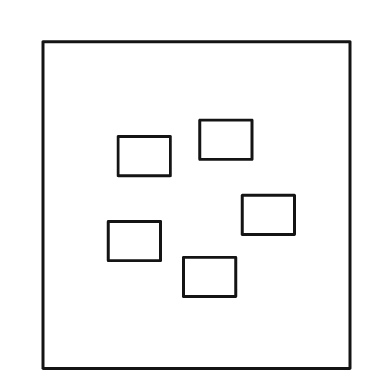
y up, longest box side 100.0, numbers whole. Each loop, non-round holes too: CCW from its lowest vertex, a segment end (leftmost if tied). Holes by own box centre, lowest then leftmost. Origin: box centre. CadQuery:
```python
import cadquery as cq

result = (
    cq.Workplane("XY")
    .moveTo(-47.0, -50.0)
    .lineTo(47.0, -50.0)
    .lineTo(47.0, 50.0)
    .lineTo(-47.0, 50.0)
    .close()
    .moveTo(-4.0, -28.0)
    .lineTo(12.0, -28.0)
    .lineTo(12.0, -16.0)
    .lineTo(-4.0, -16.0)
    .close()
    .moveTo(-27.0, -17.0)
    .lineTo(-11.0, -17.0)
    .lineTo(-11.0, -5.0)
    .lineTo(-27.0, -5.0)
    .close()
    .moveTo(14.0, -9.0)
    .lineTo(30.0, -9.0)
    .lineTo(30.0, 3.0)
    .lineTo(14.0, 3.0)
    .close()
    .moveTo(-24.0, 9.0)
    .lineTo(-8.0, 9.0)
    .lineTo(-8.0, 21.0)
    .lineTo(-24.0, 21.0)
    .close()
    .moveTo(1.0, 14.0)
    .lineTo(17.0, 14.0)
    .lineTo(17.0, 26.0)
    .lineTo(1.0, 26.0)
    .close()
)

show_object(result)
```